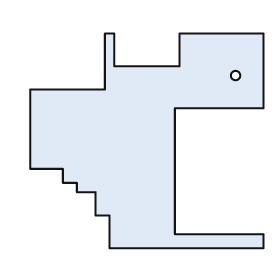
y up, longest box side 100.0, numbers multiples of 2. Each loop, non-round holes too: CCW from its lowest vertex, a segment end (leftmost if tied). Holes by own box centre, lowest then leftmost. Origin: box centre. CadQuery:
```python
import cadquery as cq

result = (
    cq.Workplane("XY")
    .moveTo(-16.0, -46.0)
    .lineTo(50.0, -46.0)
    .lineTo(50.0, -40.0)
    .lineTo(12.0, -40.0)
    .lineTo(12.0, 14.0)
    .lineTo(50.0, 14.0)
    .lineTo(50.0, 46.0)
    .lineTo(14.0, 46.0)
    .lineTo(14.0, 32.0)
    .lineTo(-14.0, 32.0)
    .lineTo(-14.0, 46.0)
    .lineTo(-18.0, 46.0)
    .lineTo(-18.0, 22.0)
    .lineTo(-50.0, 22.0)
    .lineTo(-50.0, -12.0)
    .lineTo(-36.0, -12.0)
    .lineTo(-36.0, -18.0)
    .lineTo(-30.0, -18.0)
    .lineTo(-30.0, -22.0)
    .lineTo(-22.0, -22.0)
    .lineTo(-22.0, -32.0)
    .lineTo(-16.0, -32.0)
    .close()
    .moveTo(38.0, 28.0)
    .circle(2.0)
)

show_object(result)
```